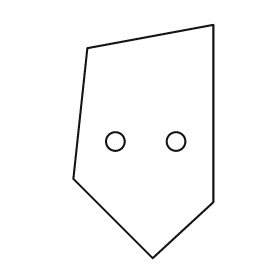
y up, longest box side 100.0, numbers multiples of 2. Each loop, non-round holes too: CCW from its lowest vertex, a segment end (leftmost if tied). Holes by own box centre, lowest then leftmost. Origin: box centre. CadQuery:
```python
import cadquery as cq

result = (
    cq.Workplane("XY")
    .moveTo(4.0, -50.0)
    .lineTo(30.0, -26.0)
    .lineTo(30.0, 50.0)
    .lineTo(-24.0, 40.0)
    .lineTo(-30.0, -16.0)
    .close()
    .moveTo(-12.0, 0.0)
    .circle(4.0)
    .moveTo(14.0, 0.0)
    .circle(4.0)
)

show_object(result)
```